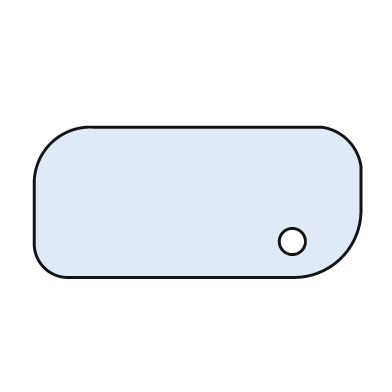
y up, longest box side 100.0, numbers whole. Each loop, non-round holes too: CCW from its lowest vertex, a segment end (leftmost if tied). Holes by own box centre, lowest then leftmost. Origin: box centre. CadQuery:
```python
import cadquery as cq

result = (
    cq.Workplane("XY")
    .moveTo(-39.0, -23.0)
    .lineTo(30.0, -23.0)
    .threePointArc((44.0, -17.0), (50.0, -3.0))
    .lineTo(50.0, 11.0)
    .threePointArc((46.0, 19.0), (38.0, 23.0))
    .lineTo(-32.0, 23.0)
    .threePointArc((-45.0, 18.0), (-50.0, 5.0))
    .lineTo(-50.0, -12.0)
    .threePointArc((-47.0, -20.0), (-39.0, -23.0))
    .close()
    .moveTo(29.0, -12.0)
    .circle(4.0)
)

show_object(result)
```